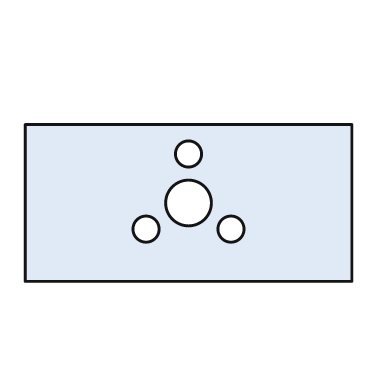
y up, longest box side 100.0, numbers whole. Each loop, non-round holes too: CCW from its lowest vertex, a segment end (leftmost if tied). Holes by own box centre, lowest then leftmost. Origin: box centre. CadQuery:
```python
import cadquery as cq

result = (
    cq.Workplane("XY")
    .moveTo(-50.0, -24.0)
    .lineTo(50.0, -24.0)
    .lineTo(50.0, 24.0)
    .lineTo(-50.0, 24.0)
    .close()
    .moveTo(-13.0, -8.0)
    .circle(4.0)
    .moveTo(13.0, -8.0)
    .circle(4.0)
    .moveTo(0.0, 0.0)
    .circle(7.0)
    .moveTo(0.0, 15.0)
    .circle(4.0)
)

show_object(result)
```